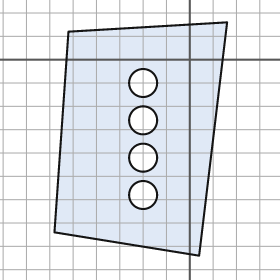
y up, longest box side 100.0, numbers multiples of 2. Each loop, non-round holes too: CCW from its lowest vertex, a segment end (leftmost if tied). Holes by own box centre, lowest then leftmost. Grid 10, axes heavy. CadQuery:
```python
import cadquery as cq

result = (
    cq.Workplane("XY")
    .moveTo(4.0, -84.0)
    .lineTo(16.0, 16.0)
    .lineTo(-52.0, 12.0)
    .lineTo(-58.0, -74.0)
    .close()
    .moveTo(-20.0, -58.0)
    .circle(6.0)
    .moveTo(-20.0, -42.0)
    .circle(6.0)
    .moveTo(-20.0, -26.0)
    .circle(6.0)
    .moveTo(-20.0, -10.0)
    .circle(6.0)
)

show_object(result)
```